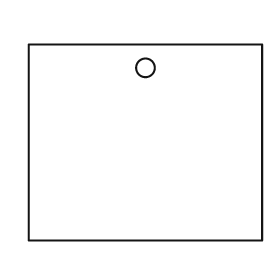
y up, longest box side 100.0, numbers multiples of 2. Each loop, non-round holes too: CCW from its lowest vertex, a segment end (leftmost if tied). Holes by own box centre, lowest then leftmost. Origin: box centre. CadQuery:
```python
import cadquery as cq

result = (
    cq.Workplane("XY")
    .moveTo(-50.0, -42.0)
    .lineTo(50.0, -42.0)
    .lineTo(50.0, 42.0)
    .lineTo(-50.0, 42.0)
    .close()
    .moveTo(0.0, 32.0)
    .circle(4.0)
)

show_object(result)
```